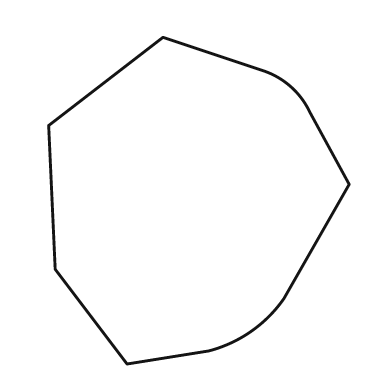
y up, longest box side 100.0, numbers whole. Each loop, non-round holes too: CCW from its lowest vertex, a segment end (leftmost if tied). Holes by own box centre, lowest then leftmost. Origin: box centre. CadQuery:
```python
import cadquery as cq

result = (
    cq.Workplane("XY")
    .moveTo(-22.0, -50.0)
    .lineTo(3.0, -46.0)
    .threePointArc((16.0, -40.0), (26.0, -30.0))
    .lineTo(46.0, 5.0)
    .lineTo(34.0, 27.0)
    .threePointArc((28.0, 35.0), (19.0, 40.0))
    .lineTo(-11.0, 50.0)
    .lineTo(-46.0, 23.0)
    .lineTo(-44.0, -21.0)
    .close()
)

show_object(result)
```